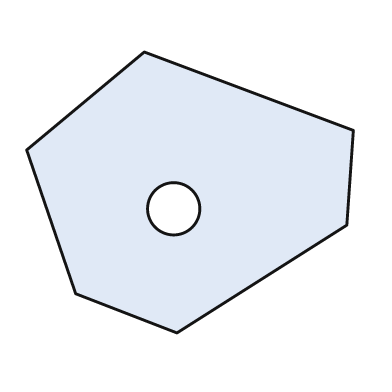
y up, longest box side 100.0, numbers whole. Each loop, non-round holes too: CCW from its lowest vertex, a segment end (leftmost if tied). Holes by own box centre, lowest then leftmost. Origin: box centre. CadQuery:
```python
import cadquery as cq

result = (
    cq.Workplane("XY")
    .moveTo(-4.0, -43.0)
    .lineTo(48.0, -10.0)
    .lineTo(50.0, 19.0)
    .lineTo(-14.0, 43.0)
    .lineTo(-50.0, 13.0)
    .lineTo(-35.0, -31.0)
    .close()
    .moveTo(-5.0, -5.0)
    .circle(8.0)
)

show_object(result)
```